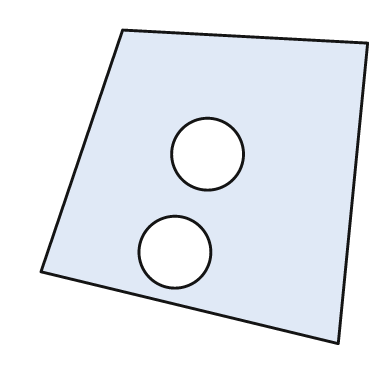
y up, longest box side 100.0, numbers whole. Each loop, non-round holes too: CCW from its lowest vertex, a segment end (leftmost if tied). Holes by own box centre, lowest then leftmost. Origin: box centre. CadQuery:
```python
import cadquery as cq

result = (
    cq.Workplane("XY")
    .moveTo(41.0, -48.0)
    .lineTo(50.0, 44.0)
    .lineTo(-25.0, 48.0)
    .lineTo(-50.0, -26.0)
    .close()
    .moveTo(-9.0, -20.0)
    .circle(11.0)
    .moveTo(1.0, 10.0)
    .circle(11.0)
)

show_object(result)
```